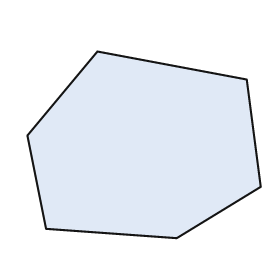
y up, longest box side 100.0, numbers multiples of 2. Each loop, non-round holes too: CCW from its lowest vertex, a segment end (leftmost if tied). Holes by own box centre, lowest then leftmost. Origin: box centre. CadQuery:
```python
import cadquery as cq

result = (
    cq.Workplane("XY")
    .moveTo(14.0, -40.0)
    .lineTo(50.0, -18.0)
    .lineTo(44.0, 28.0)
    .lineTo(-20.0, 40.0)
    .lineTo(-50.0, 4.0)
    .lineTo(-42.0, -36.0)
    .close()
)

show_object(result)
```